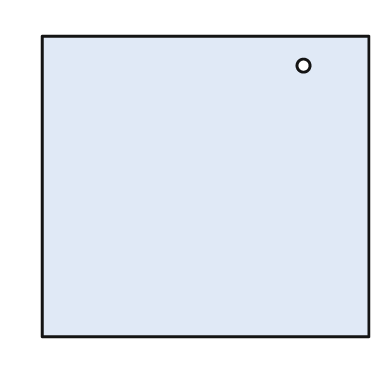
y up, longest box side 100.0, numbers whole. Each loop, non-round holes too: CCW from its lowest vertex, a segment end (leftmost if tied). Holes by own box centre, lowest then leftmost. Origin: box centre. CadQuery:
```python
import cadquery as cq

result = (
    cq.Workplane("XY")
    .moveTo(-50.0, -46.0)
    .lineTo(50.0, -46.0)
    .lineTo(50.0, 46.0)
    .lineTo(-50.0, 46.0)
    .close()
    .moveTo(30.0, 37.0)
    .circle(2.0)
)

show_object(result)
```